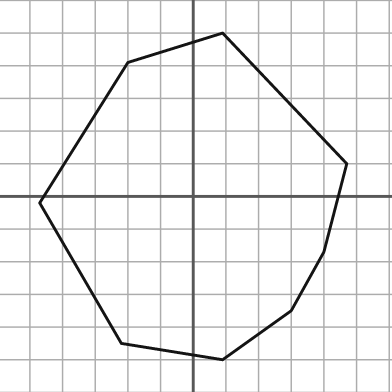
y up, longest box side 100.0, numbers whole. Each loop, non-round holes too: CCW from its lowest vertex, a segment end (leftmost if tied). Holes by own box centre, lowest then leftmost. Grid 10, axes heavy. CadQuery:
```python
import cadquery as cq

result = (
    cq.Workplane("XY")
    .moveTo(9.0, -50.0)
    .lineTo(30.0, -35.0)
    .lineTo(40.0, -17.0)
    .lineTo(47.0, 10.0)
    .lineTo(9.0, 50.0)
    .lineTo(-20.0, 41.0)
    .lineTo(-47.0, -2.0)
    .lineTo(-22.0, -45.0)
    .close()
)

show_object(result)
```